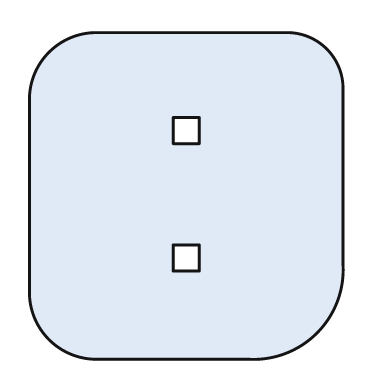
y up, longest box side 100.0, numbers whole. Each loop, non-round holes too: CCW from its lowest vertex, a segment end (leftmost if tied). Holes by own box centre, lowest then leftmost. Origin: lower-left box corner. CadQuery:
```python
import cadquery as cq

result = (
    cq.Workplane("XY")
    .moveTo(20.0, 0.0)
    .lineTo(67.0, 0.0)
    .threePointArc((88.0, 8.0), (96.0, 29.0))
    .lineTo(96.0, 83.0)
    .threePointArc((91.0, 95.0), (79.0, 100.0))
    .lineTo(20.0, 100.0)
    .threePointArc((6.0, 94.0), (0.0, 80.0))
    .lineTo(0.0, 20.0)
    .threePointArc((6.0, 6.0), (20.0, 0.0))
    .close()
    .moveTo(44.0, 27.0)
    .lineTo(52.0, 27.0)
    .lineTo(52.0, 35.0)
    .lineTo(44.0, 35.0)
    .close()
    .moveTo(44.0, 66.0)
    .lineTo(52.0, 66.0)
    .lineTo(52.0, 74.0)
    .lineTo(44.0, 74.0)
    .close()
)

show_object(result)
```